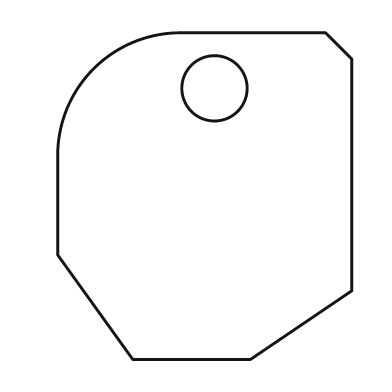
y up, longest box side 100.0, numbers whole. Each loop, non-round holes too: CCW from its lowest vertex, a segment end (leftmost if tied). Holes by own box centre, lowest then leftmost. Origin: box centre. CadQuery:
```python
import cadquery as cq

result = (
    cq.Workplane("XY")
    .moveTo(-22.0, -50.0)
    .lineTo(14.0, -50.0)
    .lineTo(45.0, -29.0)
    .lineTo(45.0, 42.0)
    .lineTo(37.0, 50.0)
    .lineTo(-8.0, 50.0)
    .threePointArc((-34.0, 39.0), (-45.0, 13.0))
    .lineTo(-45.0, -18.0)
    .close()
    .moveTo(3.0, 33.0)
    .circle(10.0)
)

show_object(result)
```